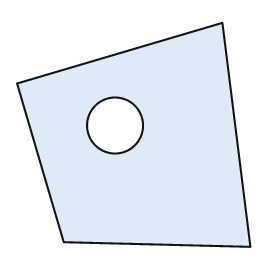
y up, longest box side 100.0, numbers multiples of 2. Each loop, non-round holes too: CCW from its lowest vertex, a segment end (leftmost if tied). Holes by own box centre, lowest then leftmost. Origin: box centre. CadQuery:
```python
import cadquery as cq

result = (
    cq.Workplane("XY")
    .moveTo(50.0, -48.0)
    .lineTo(38.0, 48.0)
    .lineTo(-50.0, 22.0)
    .lineTo(-30.0, -46.0)
    .close()
    .moveTo(-8.0, 4.0)
    .circle(12.0)
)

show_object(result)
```